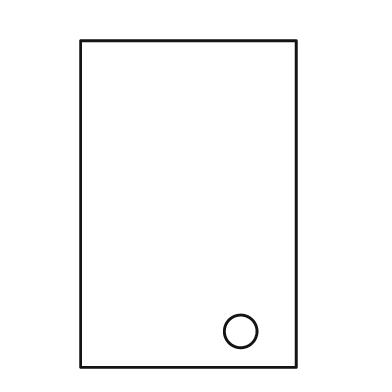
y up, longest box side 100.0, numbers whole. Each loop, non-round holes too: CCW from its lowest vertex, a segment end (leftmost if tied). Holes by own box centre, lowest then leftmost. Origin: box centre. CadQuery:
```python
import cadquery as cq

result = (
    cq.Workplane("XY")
    .moveTo(-33.0, -50.0)
    .lineTo(33.0, -50.0)
    .lineTo(33.0, 50.0)
    .lineTo(-33.0, 50.0)
    .close()
    .moveTo(16.0, -39.0)
    .circle(5.0)
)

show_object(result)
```